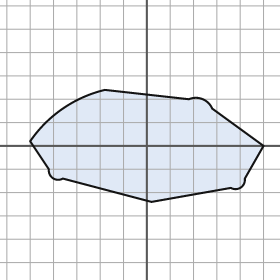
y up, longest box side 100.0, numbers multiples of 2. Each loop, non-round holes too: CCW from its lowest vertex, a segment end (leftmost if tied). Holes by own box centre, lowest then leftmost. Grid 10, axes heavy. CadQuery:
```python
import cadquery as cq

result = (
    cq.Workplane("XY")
    .moveTo(2.0, -24.0)
    .lineTo(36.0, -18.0)
    .threePointArc((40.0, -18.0), (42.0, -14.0))
    .lineTo(50.0, 0.0)
    .lineTo(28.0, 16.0)
    .threePointArc((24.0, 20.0), (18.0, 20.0))
    .lineTo(-18.0, 24.0)
    .threePointArc((-36.0, 16.0), (-50.0, 2.0))
    .lineTo(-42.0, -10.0)
    .threePointArc((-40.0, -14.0), (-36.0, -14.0))
    .close()
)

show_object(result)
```